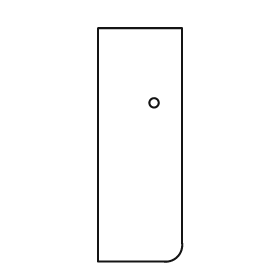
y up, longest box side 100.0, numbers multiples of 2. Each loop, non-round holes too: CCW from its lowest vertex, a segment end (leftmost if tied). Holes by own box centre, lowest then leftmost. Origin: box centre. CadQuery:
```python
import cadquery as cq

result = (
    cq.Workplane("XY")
    .moveTo(-18.0, -50.0)
    .lineTo(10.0, -50.0)
    .threePointArc((16.0, -48.0), (18.0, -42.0))
    .lineTo(18.0, 50.0)
    .lineTo(-18.0, 50.0)
    .close()
    .moveTo(6.0, 18.0)
    .circle(2.0)
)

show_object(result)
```